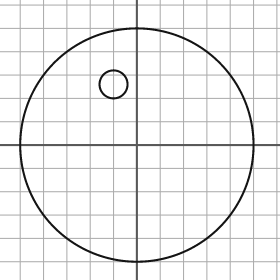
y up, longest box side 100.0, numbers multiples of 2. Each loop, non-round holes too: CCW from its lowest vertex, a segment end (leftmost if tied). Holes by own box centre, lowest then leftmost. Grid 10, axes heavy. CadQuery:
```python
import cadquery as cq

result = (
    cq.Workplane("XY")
    .moveTo(0.0, 0.0)
    .circle(50.0)
    .moveTo(-10.0, 26.0)
    .circle(6.0)
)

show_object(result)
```